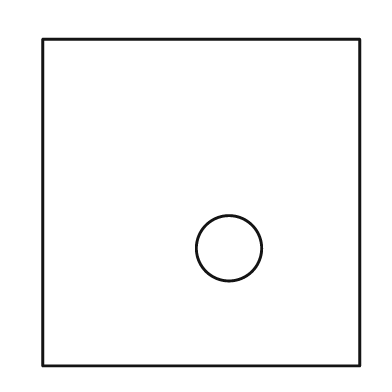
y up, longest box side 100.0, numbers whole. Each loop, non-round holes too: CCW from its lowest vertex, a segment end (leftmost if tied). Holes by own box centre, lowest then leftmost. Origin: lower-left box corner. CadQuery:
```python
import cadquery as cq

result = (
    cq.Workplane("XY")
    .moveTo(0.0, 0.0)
    .lineTo(97.0, 0.0)
    .lineTo(97.0, 100.0)
    .lineTo(0.0, 100.0)
    .close()
    .moveTo(57.0, 36.0)
    .circle(10.0)
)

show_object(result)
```